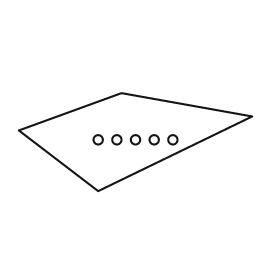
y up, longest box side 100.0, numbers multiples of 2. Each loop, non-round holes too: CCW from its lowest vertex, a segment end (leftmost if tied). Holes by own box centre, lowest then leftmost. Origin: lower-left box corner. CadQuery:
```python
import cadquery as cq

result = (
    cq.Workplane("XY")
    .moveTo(34.0, 0.0)
    .lineTo(100.0, 32.0)
    .lineTo(44.0, 42.0)
    .lineTo(0.0, 26.0)
    .close()
    .moveTo(34.0, 22.0)
    .circle(2.0)
    .moveTo(42.0, 22.0)
    .circle(2.0)
    .moveTo(50.0, 22.0)
    .circle(2.0)
    .moveTo(58.0, 22.0)
    .circle(2.0)
    .moveTo(66.0, 22.0)
    .circle(2.0)
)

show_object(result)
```